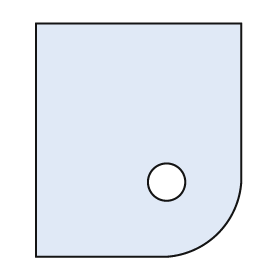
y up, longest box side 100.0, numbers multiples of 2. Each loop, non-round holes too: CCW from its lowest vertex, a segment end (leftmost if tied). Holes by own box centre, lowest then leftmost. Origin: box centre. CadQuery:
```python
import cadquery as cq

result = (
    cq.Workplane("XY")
    .moveTo(-44.0, -50.0)
    .lineTo(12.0, -50.0)
    .threePointArc((34.0, -40.0), (44.0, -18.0))
    .lineTo(44.0, 50.0)
    .lineTo(-44.0, 50.0)
    .close()
    .moveTo(12.0, -18.0)
    .circle(8.0)
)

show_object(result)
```